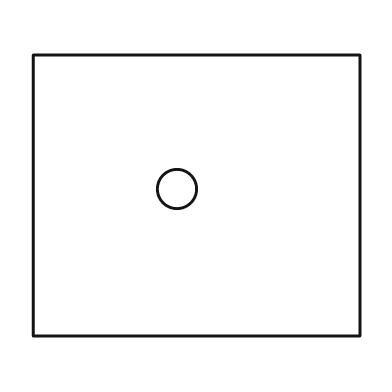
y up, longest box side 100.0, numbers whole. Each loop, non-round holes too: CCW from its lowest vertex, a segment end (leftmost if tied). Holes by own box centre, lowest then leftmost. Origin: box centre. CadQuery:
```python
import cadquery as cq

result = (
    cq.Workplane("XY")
    .moveTo(-50.0, -43.0)
    .lineTo(50.0, -43.0)
    .lineTo(50.0, 43.0)
    .lineTo(-50.0, 43.0)
    .close()
    .moveTo(-6.0, 2.0)
    .circle(6.0)
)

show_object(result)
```